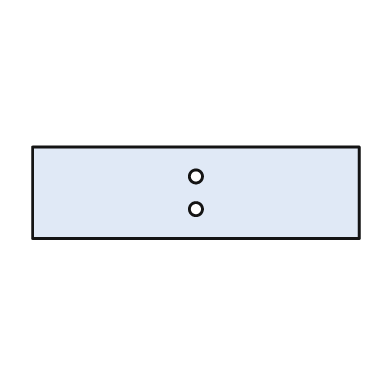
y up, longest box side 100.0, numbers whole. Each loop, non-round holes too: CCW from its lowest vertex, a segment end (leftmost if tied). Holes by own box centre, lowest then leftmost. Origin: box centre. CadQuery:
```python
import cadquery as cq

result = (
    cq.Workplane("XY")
    .moveTo(-50.0, -14.0)
    .lineTo(50.0, -14.0)
    .lineTo(50.0, 14.0)
    .lineTo(-50.0, 14.0)
    .close()
    .moveTo(0.0, -5.0)
    .circle(2.0)
    .moveTo(0.0, 5.0)
    .circle(2.0)
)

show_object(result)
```